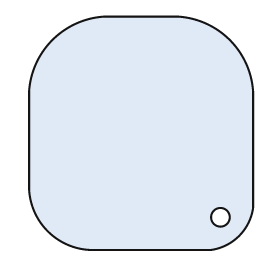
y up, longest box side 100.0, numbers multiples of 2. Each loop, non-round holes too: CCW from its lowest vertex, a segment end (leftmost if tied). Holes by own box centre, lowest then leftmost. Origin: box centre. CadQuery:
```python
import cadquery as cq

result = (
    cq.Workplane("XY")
    .moveTo(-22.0, -50.0)
    .lineTo(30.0, -50.0)
    .threePointArc((42.0, -44.0), (48.0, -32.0))
    .lineTo(48.0, 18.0)
    .threePointArc((38.0, 40.0), (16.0, 50.0))
    .lineTo(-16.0, 50.0)
    .threePointArc((-38.0, 40.0), (-48.0, 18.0))
    .lineTo(-48.0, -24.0)
    .threePointArc((-40.0, -42.0), (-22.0, -50.0))
    .close()
    .moveTo(34.0, -36.0)
    .circle(4.0)
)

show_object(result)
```